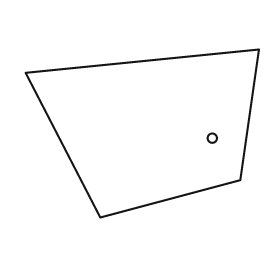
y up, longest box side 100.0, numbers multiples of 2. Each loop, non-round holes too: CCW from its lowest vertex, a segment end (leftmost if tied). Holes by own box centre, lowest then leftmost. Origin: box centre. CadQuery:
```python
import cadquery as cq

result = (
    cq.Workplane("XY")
    .moveTo(-18.0, -36.0)
    .lineTo(42.0, -20.0)
    .lineTo(50.0, 36.0)
    .lineTo(-50.0, 26.0)
    .close()
    .moveTo(30.0, -2.0)
    .circle(2.0)
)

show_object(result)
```